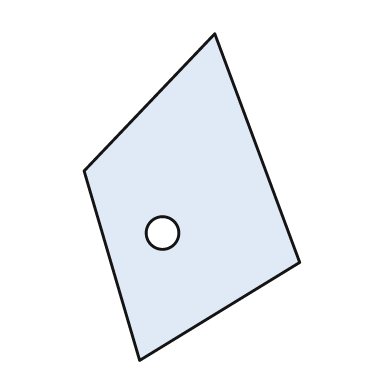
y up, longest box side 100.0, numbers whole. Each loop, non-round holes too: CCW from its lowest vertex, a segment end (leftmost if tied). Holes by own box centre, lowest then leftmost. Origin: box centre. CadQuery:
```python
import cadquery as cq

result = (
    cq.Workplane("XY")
    .moveTo(-16.0, -50.0)
    .lineTo(33.0, -20.0)
    .lineTo(7.0, 50.0)
    .lineTo(-33.0, 8.0)
    .close()
    .moveTo(-9.0, -11.0)
    .circle(5.0)
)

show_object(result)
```